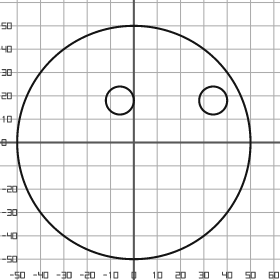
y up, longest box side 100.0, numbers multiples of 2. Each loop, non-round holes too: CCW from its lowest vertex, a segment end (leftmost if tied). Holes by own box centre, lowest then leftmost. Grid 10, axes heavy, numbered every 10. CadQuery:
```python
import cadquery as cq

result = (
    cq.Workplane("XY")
    .moveTo(0.0, 0.0)
    .circle(50.0)
    .moveTo(-6.0, 18.0)
    .circle(6.0)
    .moveTo(34.0, 18.0)
    .circle(6.0)
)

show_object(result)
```